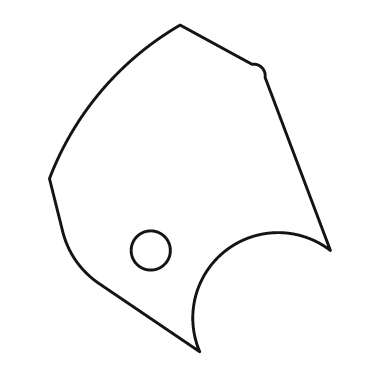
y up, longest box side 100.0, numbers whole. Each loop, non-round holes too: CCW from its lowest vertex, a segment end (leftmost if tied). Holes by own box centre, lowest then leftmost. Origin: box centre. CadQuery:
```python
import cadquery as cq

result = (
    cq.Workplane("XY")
    .moveTo(3.0, -50.0)
    .threePointArc((11.0, -19.0), (43.0, -19.0))
    .lineTo(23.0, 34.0)
    .threePointArc((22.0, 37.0), (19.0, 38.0))
    .lineTo(-3.0, 50.0)
    .threePointArc((-27.0, 30.0), (-43.0, 3.0))
    .lineTo(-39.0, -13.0)
    .threePointArc((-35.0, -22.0), (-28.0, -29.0))
    .close()
    .moveTo(-12.0, -19.0)
    .circle(6.0)
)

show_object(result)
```